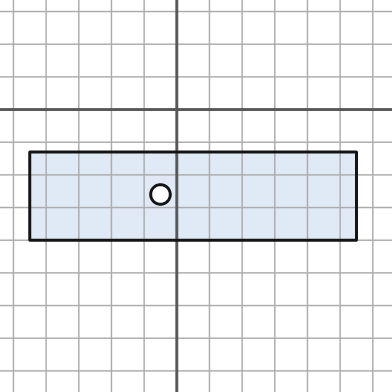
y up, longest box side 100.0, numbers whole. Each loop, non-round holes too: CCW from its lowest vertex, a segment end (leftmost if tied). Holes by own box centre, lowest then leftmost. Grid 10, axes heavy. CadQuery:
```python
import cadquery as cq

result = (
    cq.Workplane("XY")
    .moveTo(-45.0, -40.0)
    .lineTo(55.0, -40.0)
    .lineTo(55.0, -13.0)
    .lineTo(-45.0, -13.0)
    .close()
    .moveTo(-5.0, -26.0)
    .circle(3.0)
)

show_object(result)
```